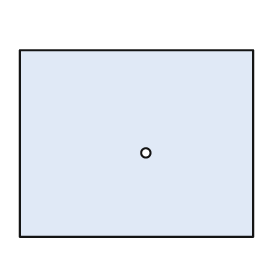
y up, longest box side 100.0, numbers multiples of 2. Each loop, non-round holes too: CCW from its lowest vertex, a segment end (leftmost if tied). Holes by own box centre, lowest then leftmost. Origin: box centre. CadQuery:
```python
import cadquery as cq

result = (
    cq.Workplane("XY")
    .moveTo(-50.0, -40.0)
    .lineTo(50.0, -40.0)
    .lineTo(50.0, 40.0)
    .lineTo(-50.0, 40.0)
    .close()
    .moveTo(4.0, -4.0)
    .circle(2.0)
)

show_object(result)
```